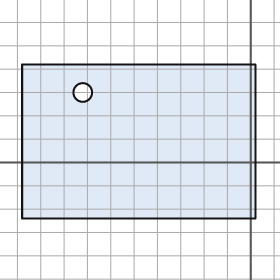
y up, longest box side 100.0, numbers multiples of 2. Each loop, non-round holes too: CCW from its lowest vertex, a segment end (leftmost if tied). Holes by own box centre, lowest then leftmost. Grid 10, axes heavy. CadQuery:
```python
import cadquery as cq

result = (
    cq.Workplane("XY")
    .moveTo(-98.0, -24.0)
    .lineTo(2.0, -24.0)
    .lineTo(2.0, 42.0)
    .lineTo(-98.0, 42.0)
    .close()
    .moveTo(-72.0, 30.0)
    .circle(4.0)
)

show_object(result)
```